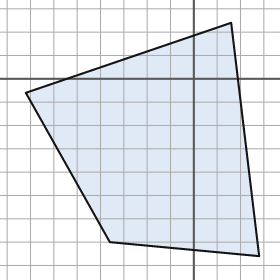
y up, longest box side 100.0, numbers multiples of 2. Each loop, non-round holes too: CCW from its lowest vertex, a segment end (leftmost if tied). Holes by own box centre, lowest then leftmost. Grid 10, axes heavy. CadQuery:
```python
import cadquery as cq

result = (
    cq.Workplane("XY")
    .moveTo(28.0, -76.0)
    .lineTo(16.0, 24.0)
    .lineTo(-72.0, -6.0)
    .lineTo(-36.0, -70.0)
    .close()
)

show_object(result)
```